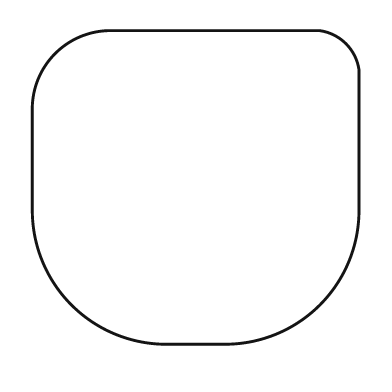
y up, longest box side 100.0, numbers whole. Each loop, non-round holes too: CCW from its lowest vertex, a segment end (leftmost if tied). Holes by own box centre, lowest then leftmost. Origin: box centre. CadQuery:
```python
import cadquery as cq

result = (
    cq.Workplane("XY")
    .moveTo(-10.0, -48.0)
    .lineTo(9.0, -48.0)
    .threePointArc((38.0, -36.0), (50.0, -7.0))
    .lineTo(50.0, 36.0)
    .threePointArc((46.0, 44.0), (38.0, 48.0))
    .lineTo(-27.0, 48.0)
    .threePointArc((-43.0, 41.0), (-50.0, 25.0))
    .lineTo(-50.0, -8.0)
    .threePointArc((-38.0, -36.0), (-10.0, -48.0))
    .close()
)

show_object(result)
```